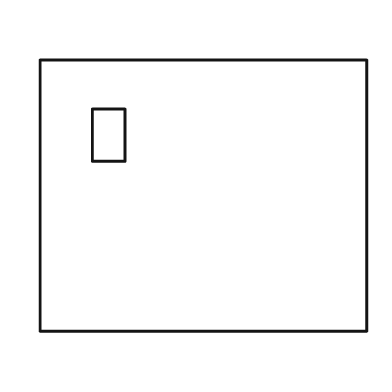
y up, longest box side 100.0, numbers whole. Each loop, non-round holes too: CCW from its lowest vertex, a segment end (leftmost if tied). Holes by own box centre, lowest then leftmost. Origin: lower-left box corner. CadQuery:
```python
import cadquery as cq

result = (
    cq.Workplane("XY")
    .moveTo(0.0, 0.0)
    .lineTo(100.0, 0.0)
    .lineTo(100.0, 83.0)
    .lineTo(0.0, 83.0)
    .close()
    .moveTo(16.0, 52.0)
    .lineTo(26.0, 52.0)
    .lineTo(26.0, 68.0)
    .lineTo(16.0, 68.0)
    .close()
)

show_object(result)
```